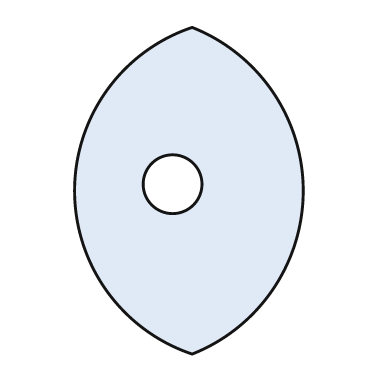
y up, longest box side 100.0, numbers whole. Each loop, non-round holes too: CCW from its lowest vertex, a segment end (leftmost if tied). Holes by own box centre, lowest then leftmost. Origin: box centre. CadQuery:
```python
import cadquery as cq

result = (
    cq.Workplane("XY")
    .moveTo(1.0, -50.0)
    .threePointArc((35.0, 0.0), (1.0, 50.0))
    .threePointArc((-35.0, 0.0), (1.0, -50.0))
    .close()
    .moveTo(-5.0, 2.0)
    .circle(9.0)
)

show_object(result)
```